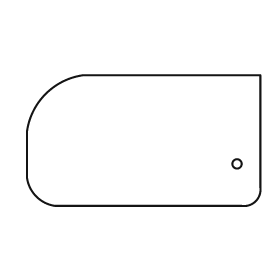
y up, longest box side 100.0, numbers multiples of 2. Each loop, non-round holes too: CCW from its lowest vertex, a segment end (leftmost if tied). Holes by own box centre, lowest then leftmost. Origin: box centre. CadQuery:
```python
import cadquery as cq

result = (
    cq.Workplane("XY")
    .moveTo(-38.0, -28.0)
    .lineTo(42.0, -28.0)
    .threePointArc((48.0, -26.0), (50.0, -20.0))
    .lineTo(50.0, 28.0)
    .lineTo(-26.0, 28.0)
    .threePointArc((-42.0, 20.0), (-50.0, 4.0))
    .lineTo(-50.0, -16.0)
    .threePointArc((-46.0, -24.0), (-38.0, -28.0))
    .close()
    .moveTo(40.0, -10.0)
    .circle(2.0)
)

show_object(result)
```